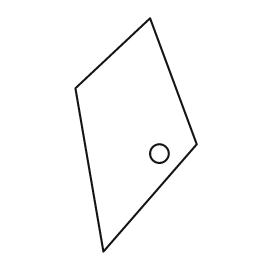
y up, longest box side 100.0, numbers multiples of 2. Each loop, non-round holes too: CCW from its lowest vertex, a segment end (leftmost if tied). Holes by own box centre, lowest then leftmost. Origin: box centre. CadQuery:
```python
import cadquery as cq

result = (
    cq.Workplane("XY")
    .moveTo(-14.0, -50.0)
    .lineTo(26.0, -4.0)
    .lineTo(6.0, 50.0)
    .lineTo(-26.0, 20.0)
    .close()
    .moveTo(10.0, -8.0)
    .circle(4.0)
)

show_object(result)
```